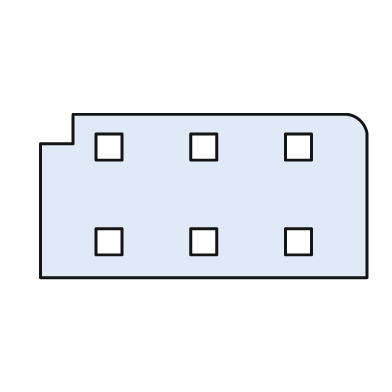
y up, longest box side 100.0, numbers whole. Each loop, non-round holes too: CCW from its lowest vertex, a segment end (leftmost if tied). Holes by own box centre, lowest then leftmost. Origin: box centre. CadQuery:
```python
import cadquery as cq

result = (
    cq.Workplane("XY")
    .moveTo(-50.0, -25.0)
    .lineTo(50.0, -25.0)
    .lineTo(50.0, 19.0)
    .threePointArc((48.0, 23.0), (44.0, 25.0))
    .lineTo(-40.0, 25.0)
    .lineTo(-40.0, 16.0)
    .lineTo(-50.0, 16.0)
    .close()
    .moveTo(-33.0, -18.0)
    .lineTo(-25.0, -18.0)
    .lineTo(-25.0, -10.0)
    .lineTo(-33.0, -10.0)
    .close()
    .moveTo(-4.0, -18.0)
    .lineTo(4.0, -18.0)
    .lineTo(4.0, -10.0)
    .lineTo(-4.0, -10.0)
    .close()
    .moveTo(25.0, -18.0)
    .lineTo(33.0, -18.0)
    .lineTo(33.0, -10.0)
    .lineTo(25.0, -10.0)
    .close()
    .moveTo(-33.0, 11.0)
    .lineTo(-25.0, 11.0)
    .lineTo(-25.0, 19.0)
    .lineTo(-33.0, 19.0)
    .close()
    .moveTo(-4.0, 11.0)
    .lineTo(4.0, 11.0)
    .lineTo(4.0, 19.0)
    .lineTo(-4.0, 19.0)
    .close()
    .moveTo(25.0, 11.0)
    .lineTo(33.0, 11.0)
    .lineTo(33.0, 19.0)
    .lineTo(25.0, 19.0)
    .close()
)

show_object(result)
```